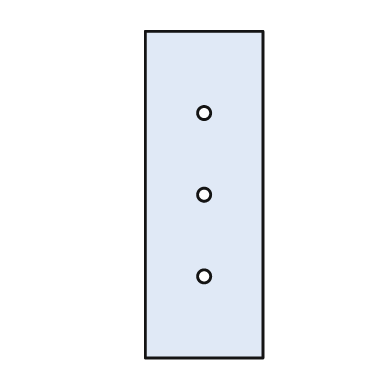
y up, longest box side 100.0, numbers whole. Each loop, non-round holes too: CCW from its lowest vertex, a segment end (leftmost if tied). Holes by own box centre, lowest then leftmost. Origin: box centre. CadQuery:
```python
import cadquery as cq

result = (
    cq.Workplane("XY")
    .moveTo(-18.0, -50.0)
    .lineTo(18.0, -50.0)
    .lineTo(18.0, 50.0)
    .lineTo(-18.0, 50.0)
    .close()
    .moveTo(0.0, -25.0)
    .circle(2.0)
    .moveTo(0.0, 0.0)
    .circle(2.0)
    .moveTo(0.0, 25.0)
    .circle(2.0)
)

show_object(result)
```